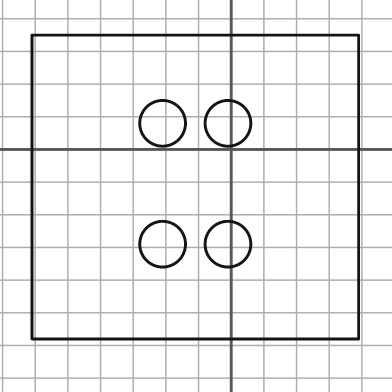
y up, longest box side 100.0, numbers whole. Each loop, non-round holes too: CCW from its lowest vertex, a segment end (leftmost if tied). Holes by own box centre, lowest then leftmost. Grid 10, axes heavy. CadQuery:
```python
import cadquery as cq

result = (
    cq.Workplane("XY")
    .moveTo(-61.0, -58.0)
    .lineTo(39.0, -58.0)
    .lineTo(39.0, 35.0)
    .lineTo(-61.0, 35.0)
    .close()
    .moveTo(-21.0, -29.0)
    .circle(7.0)
    .moveTo(-1.0, -29.0)
    .circle(7.0)
    .moveTo(-21.0, 8.0)
    .circle(7.0)
    .moveTo(-1.0, 8.0)
    .circle(7.0)
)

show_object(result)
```